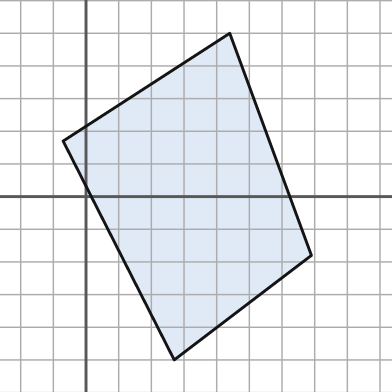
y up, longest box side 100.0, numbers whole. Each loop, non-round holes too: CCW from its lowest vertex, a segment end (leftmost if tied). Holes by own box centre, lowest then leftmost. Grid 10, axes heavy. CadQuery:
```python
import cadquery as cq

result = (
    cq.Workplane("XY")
    .moveTo(27.0, -50.0)
    .lineTo(69.0, -18.0)
    .lineTo(44.0, 50.0)
    .lineTo(-7.0, 17.0)
    .close()
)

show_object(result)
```